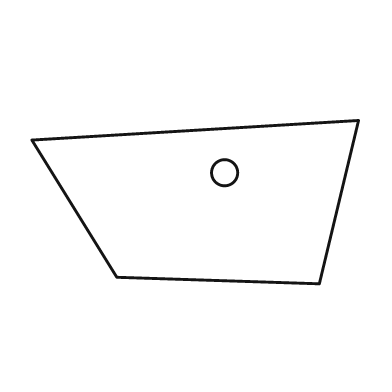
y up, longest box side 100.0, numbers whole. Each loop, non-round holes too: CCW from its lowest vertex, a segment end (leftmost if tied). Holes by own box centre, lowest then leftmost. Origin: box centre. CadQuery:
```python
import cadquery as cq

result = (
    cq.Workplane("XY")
    .moveTo(38.0, -25.0)
    .lineTo(50.0, 25.0)
    .lineTo(-50.0, 19.0)
    .lineTo(-24.0, -23.0)
    .close()
    .moveTo(9.0, 9.0)
    .circle(4.0)
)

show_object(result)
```